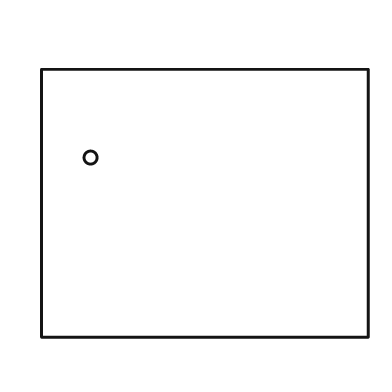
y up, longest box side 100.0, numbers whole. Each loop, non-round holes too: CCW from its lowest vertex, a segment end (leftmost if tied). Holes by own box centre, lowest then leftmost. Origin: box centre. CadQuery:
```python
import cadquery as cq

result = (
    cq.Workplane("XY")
    .moveTo(-50.0, -41.0)
    .lineTo(50.0, -41.0)
    .lineTo(50.0, 41.0)
    .lineTo(-50.0, 41.0)
    .close()
    .moveTo(-35.0, 14.0)
    .circle(2.0)
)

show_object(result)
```